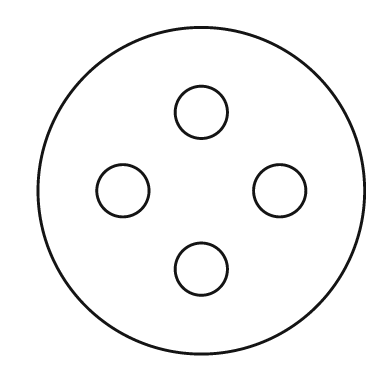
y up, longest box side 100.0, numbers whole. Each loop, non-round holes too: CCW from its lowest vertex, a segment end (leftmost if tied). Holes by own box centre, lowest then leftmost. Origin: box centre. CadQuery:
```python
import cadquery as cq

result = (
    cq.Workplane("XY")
    .moveTo(0.0, 0.0)
    .circle(50.0)
    .moveTo(0.0, -24.0)
    .circle(8.0)
    .moveTo(-24.0, 0.0)
    .circle(8.0)
    .moveTo(24.0, 0.0)
    .circle(8.0)
    .moveTo(0.0, 24.0)
    .circle(8.0)
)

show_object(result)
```